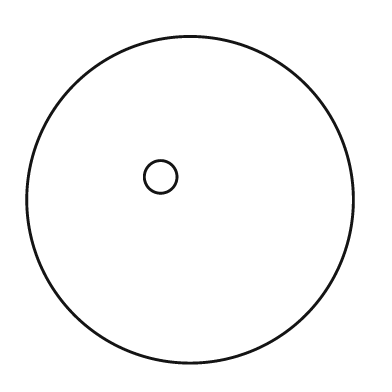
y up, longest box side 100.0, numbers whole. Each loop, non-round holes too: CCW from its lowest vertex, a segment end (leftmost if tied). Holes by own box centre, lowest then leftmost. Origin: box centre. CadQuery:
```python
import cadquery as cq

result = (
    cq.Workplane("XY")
    .moveTo(0.0, 0.0)
    .circle(50.0)
    .moveTo(-9.0, 7.0)
    .circle(5.0)
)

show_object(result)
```